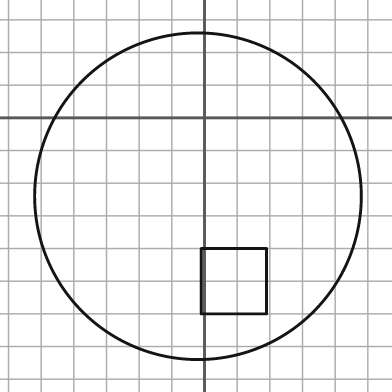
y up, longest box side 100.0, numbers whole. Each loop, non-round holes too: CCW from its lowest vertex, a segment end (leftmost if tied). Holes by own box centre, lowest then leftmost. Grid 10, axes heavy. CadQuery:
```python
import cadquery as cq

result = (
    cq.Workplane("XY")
    .moveTo(-2.0, -24.0)
    .circle(50.0)
    .moveTo(-1.0, -60.0)
    .lineTo(19.0, -60.0)
    .lineTo(19.0, -40.0)
    .lineTo(-1.0, -40.0)
    .close()
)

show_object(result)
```